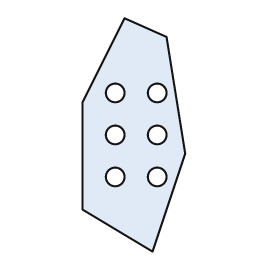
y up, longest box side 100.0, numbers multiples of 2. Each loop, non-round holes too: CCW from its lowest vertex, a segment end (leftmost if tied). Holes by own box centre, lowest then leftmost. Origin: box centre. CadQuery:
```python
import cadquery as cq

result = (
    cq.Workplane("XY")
    .moveTo(8.0, -50.0)
    .lineTo(22.0, -8.0)
    .lineTo(14.0, 42.0)
    .lineTo(-4.0, 50.0)
    .lineTo(-22.0, 14.0)
    .lineTo(-22.0, -32.0)
    .close()
    .moveTo(-8.0, -18.0)
    .circle(4.0)
    .moveTo(10.0, -18.0)
    .circle(4.0)
    .moveTo(-8.0, 0.0)
    .circle(4.0)
    .moveTo(10.0, 0.0)
    .circle(4.0)
    .moveTo(-8.0, 18.0)
    .circle(4.0)
    .moveTo(10.0, 18.0)
    .circle(4.0)
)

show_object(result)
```